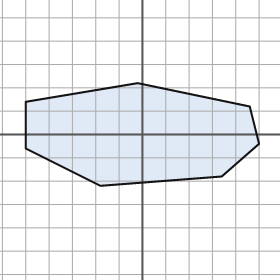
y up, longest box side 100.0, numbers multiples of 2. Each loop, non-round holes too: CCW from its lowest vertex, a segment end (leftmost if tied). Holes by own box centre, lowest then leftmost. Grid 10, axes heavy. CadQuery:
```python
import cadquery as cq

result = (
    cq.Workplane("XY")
    .moveTo(-18.0, -22.0)
    .lineTo(34.0, -18.0)
    .lineTo(50.0, -4.0)
    .lineTo(46.0, 12.0)
    .lineTo(-2.0, 22.0)
    .lineTo(-50.0, 14.0)
    .lineTo(-50.0, -6.0)
    .close()
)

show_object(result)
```